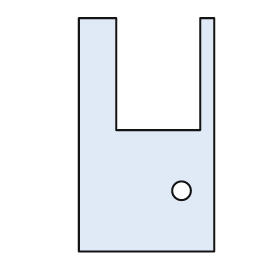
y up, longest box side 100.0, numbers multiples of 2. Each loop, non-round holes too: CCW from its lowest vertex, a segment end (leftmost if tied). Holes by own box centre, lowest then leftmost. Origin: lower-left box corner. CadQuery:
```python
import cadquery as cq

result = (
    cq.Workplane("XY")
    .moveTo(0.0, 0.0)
    .lineTo(58.0, 0.0)
    .lineTo(58.0, 100.0)
    .lineTo(52.0, 100.0)
    .lineTo(52.0, 52.0)
    .lineTo(16.0, 52.0)
    .lineTo(16.0, 100.0)
    .lineTo(0.0, 100.0)
    .close()
    .moveTo(44.0, 26.0)
    .circle(4.0)
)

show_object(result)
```